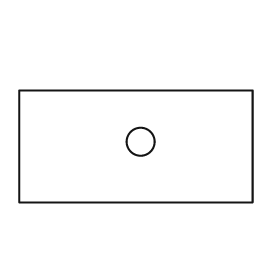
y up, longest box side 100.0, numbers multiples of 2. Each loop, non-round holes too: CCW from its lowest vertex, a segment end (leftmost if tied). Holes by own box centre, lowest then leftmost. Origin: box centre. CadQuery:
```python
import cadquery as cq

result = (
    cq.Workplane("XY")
    .moveTo(-50.0, -24.0)
    .lineTo(50.0, -24.0)
    .lineTo(50.0, 24.0)
    .lineTo(-50.0, 24.0)
    .close()
    .moveTo(2.0, 2.0)
    .circle(6.0)
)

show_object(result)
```